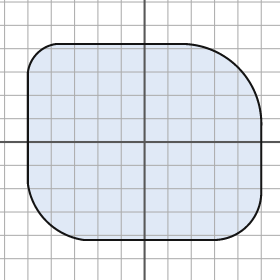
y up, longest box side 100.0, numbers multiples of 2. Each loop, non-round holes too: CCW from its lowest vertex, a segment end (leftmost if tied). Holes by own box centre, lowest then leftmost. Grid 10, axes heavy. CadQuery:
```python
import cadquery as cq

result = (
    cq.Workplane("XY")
    .moveTo(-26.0, -42.0)
    .lineTo(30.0, -42.0)
    .threePointArc((44.0, -36.0), (50.0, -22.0))
    .lineTo(50.0, 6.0)
    .threePointArc((40.0, 32.0), (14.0, 42.0))
    .lineTo(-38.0, 42.0)
    .threePointArc((-46.0, 38.0), (-50.0, 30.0))
    .lineTo(-50.0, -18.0)
    .threePointArc((-42.0, -34.0), (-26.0, -42.0))
    .close()
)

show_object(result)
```